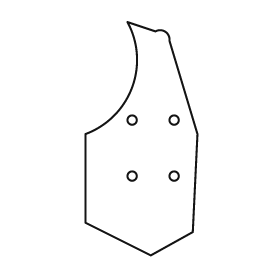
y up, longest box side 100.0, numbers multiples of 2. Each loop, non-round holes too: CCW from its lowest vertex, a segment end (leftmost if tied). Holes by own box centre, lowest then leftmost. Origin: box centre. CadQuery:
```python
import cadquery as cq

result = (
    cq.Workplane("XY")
    .moveTo(4.0, -50.0)
    .lineTo(22.0, -40.0)
    .lineTo(24.0, 2.0)
    .lineTo(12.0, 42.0)
    .threePointArc((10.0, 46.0), (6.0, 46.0))
    .lineTo(-6.0, 50.0)
    .threePointArc((-4.0, 22.0), (-24.0, 2.0))
    .lineTo(-24.0, -36.0)
    .close()
    .moveTo(-4.0, -16.0)
    .circle(2.0)
    .moveTo(14.0, -16.0)
    .circle(2.0)
    .moveTo(-4.0, 8.0)
    .circle(2.0)
    .moveTo(14.0, 8.0)
    .circle(2.0)
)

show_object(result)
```